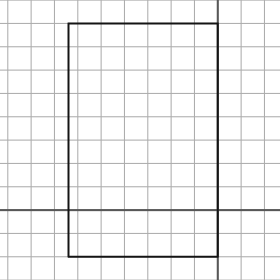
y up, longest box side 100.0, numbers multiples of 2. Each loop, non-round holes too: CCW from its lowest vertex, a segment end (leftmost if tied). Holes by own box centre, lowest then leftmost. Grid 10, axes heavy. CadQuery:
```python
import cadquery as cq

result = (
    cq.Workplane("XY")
    .moveTo(-64.0, -20.0)
    .lineTo(0.0, -20.0)
    .lineTo(0.0, 80.0)
    .lineTo(-64.0, 80.0)
    .close()
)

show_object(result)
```